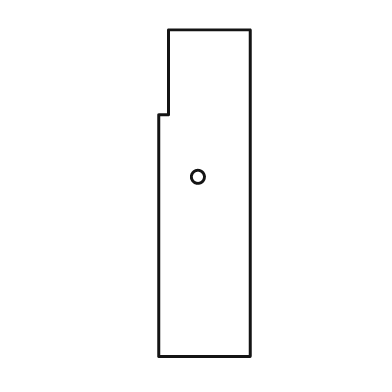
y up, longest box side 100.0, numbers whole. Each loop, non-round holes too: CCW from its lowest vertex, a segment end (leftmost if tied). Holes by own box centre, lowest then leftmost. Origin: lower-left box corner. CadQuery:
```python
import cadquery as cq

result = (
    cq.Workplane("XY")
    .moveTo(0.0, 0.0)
    .lineTo(28.0, 0.0)
    .lineTo(28.0, 100.0)
    .lineTo(3.0, 100.0)
    .lineTo(3.0, 74.0)
    .lineTo(0.0, 74.0)
    .close()
    .moveTo(12.0, 55.0)
    .circle(2.0)
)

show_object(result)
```